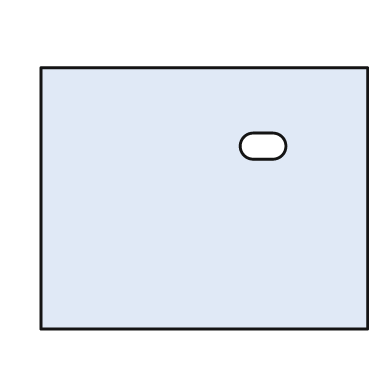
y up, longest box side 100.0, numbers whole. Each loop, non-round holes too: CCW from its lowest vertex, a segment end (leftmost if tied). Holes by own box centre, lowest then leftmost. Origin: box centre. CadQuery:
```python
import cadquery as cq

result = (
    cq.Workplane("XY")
    .moveTo(-50.0, -40.0)
    .lineTo(50.0, -40.0)
    .lineTo(50.0, 40.0)
    .lineTo(-50.0, 40.0)
    .close()
    .moveTo(15.0, 12.0)
    .lineTo(21.0, 12.0)
    .threePointArc((25.0, 16.0), (21.0, 20.0))
    .lineTo(15.0, 20.0)
    .threePointArc((11.0, 16.0), (15.0, 12.0))
    .close()
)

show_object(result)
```